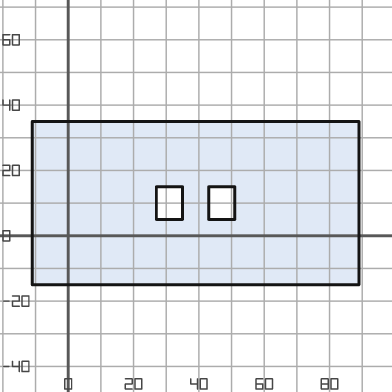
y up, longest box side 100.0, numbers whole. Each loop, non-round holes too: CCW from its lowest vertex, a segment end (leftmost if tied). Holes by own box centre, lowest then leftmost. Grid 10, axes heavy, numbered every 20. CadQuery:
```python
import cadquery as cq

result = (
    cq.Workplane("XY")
    .moveTo(-11.0, -15.0)
    .lineTo(89.0, -15.0)
    .lineTo(89.0, 35.0)
    .lineTo(-11.0, 35.0)
    .close()
    .moveTo(27.0, 5.0)
    .lineTo(35.0, 5.0)
    .lineTo(35.0, 15.0)
    .lineTo(27.0, 15.0)
    .close()
    .moveTo(43.0, 5.0)
    .lineTo(51.0, 5.0)
    .lineTo(51.0, 15.0)
    .lineTo(43.0, 15.0)
    .close()
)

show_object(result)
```